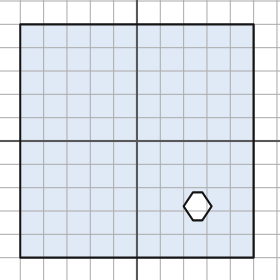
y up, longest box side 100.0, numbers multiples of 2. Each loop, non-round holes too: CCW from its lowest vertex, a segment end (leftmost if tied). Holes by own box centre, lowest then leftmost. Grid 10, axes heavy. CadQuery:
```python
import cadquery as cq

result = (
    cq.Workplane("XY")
    .moveTo(-50.0, -50.0)
    .lineTo(50.0, -50.0)
    .lineTo(50.0, 50.0)
    .lineTo(-50.0, 50.0)
    .close()
    .moveTo(24.0, -34.0)
    .lineTo(28.0, -34.0)
    .lineTo(32.0, -28.0)
    .lineTo(28.0, -22.0)
    .lineTo(24.0, -22.0)
    .lineTo(20.0, -28.0)
    .close()
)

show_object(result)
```